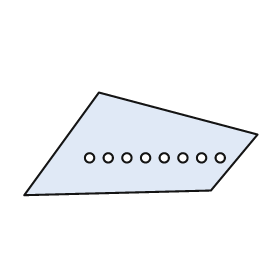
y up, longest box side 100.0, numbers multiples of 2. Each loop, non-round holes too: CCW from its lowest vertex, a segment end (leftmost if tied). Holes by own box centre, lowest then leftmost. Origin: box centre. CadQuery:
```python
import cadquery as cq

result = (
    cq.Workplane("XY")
    .moveTo(-50.0, -22.0)
    .lineTo(30.0, -20.0)
    .lineTo(50.0, 4.0)
    .lineTo(-18.0, 22.0)
    .close()
    .moveTo(-22.0, -6.0)
    .circle(2.0)
    .moveTo(-14.0, -6.0)
    .circle(2.0)
    .moveTo(-6.0, -6.0)
    .circle(2.0)
    .moveTo(2.0, -6.0)
    .circle(2.0)
    .moveTo(10.0, -6.0)
    .circle(2.0)
    .moveTo(18.0, -6.0)
    .circle(2.0)
    .moveTo(26.0, -6.0)
    .circle(2.0)
    .moveTo(34.0, -6.0)
    .circle(2.0)
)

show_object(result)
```